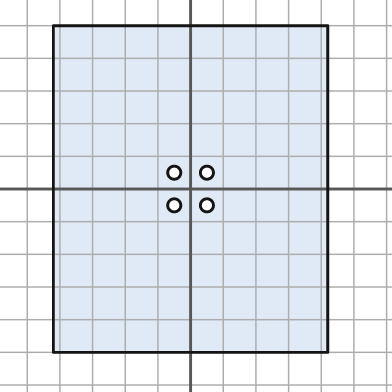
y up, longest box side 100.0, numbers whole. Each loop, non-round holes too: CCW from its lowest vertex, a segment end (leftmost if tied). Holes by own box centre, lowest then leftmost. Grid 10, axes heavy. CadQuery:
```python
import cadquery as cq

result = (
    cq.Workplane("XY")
    .moveTo(-42.0, -50.0)
    .lineTo(42.0, -50.0)
    .lineTo(42.0, 50.0)
    .lineTo(-42.0, 50.0)
    .close()
    .moveTo(-5.0, -5.0)
    .circle(2.0)
    .moveTo(5.0, -5.0)
    .circle(2.0)
    .moveTo(-5.0, 5.0)
    .circle(2.0)
    .moveTo(5.0, 5.0)
    .circle(2.0)
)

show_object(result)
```